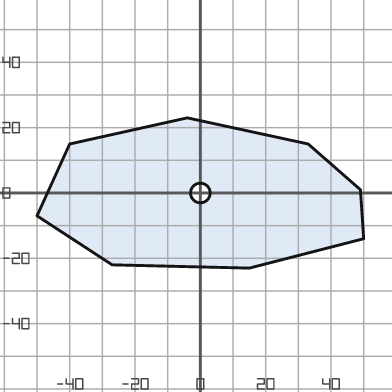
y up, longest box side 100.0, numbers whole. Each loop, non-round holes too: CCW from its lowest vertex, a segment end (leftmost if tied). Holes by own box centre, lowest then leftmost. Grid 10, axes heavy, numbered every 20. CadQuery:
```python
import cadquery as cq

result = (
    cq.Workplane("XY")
    .moveTo(15.0, -23.0)
    .lineTo(50.0, -14.0)
    .lineTo(49.0, 1.0)
    .lineTo(33.0, 15.0)
    .lineTo(-4.0, 23.0)
    .lineTo(-40.0, 15.0)
    .lineTo(-50.0, -7.0)
    .lineTo(-27.0, -22.0)
    .close()
    .moveTo(0.0, 0.0)
    .circle(3.0)
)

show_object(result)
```